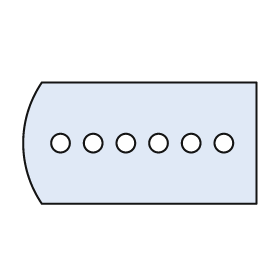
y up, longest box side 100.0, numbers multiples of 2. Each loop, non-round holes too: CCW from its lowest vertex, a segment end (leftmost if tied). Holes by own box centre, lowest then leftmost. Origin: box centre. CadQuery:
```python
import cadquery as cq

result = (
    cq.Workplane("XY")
    .moveTo(-42.0, -26.0)
    .lineTo(50.0, -26.0)
    .lineTo(50.0, 26.0)
    .lineTo(-42.0, 26.0)
    .threePointArc((-50.0, 0.0), (-42.0, -26.0))
    .close()
    .moveTo(-34.0, 0.0)
    .circle(4.0)
    .moveTo(-20.0, 0.0)
    .circle(4.0)
    .moveTo(-6.0, 0.0)
    .circle(4.0)
    .moveTo(8.0, 0.0)
    .circle(4.0)
    .moveTo(22.0, 0.0)
    .circle(4.0)
    .moveTo(36.0, 0.0)
    .circle(4.0)
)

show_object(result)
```